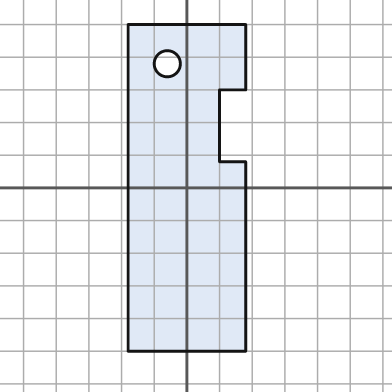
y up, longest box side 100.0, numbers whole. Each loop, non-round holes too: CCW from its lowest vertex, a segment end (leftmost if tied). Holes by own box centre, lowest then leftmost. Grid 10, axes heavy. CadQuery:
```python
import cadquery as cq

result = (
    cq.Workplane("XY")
    .moveTo(-18.0, -50.0)
    .lineTo(18.0, -50.0)
    .lineTo(18.0, 8.0)
    .lineTo(10.0, 8.0)
    .lineTo(10.0, 30.0)
    .lineTo(18.0, 30.0)
    .lineTo(18.0, 50.0)
    .lineTo(-18.0, 50.0)
    .close()
    .moveTo(-6.0, 38.0)
    .circle(4.0)
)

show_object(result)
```